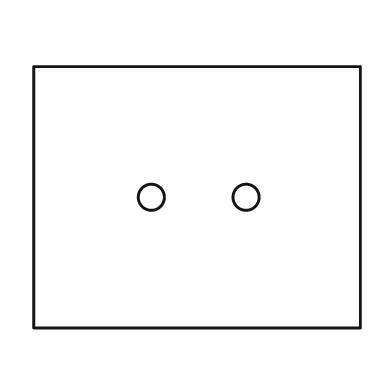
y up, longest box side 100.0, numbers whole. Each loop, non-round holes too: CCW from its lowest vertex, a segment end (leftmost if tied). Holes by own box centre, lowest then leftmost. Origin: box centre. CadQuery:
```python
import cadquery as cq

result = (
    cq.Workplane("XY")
    .moveTo(-50.0, -40.0)
    .lineTo(50.0, -40.0)
    .lineTo(50.0, 40.0)
    .lineTo(-50.0, 40.0)
    .close()
    .moveTo(-14.0, 0.0)
    .circle(4.0)
    .moveTo(15.0, 0.0)
    .circle(4.0)
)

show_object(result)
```